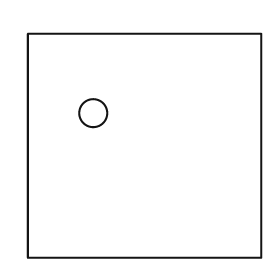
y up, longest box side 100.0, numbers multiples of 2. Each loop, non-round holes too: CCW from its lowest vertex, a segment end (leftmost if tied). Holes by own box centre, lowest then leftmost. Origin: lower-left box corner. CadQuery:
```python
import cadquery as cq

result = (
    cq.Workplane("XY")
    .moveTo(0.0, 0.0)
    .lineTo(100.0, 0.0)
    .lineTo(100.0, 96.0)
    .lineTo(0.0, 96.0)
    .close()
    .moveTo(28.0, 62.0)
    .circle(6.0)
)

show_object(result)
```